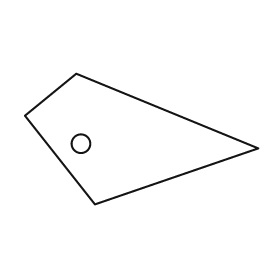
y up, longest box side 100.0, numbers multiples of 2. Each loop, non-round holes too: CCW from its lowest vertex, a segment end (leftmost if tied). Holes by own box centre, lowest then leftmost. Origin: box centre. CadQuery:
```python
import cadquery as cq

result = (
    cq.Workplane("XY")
    .moveTo(-20.0, -28.0)
    .lineTo(50.0, -4.0)
    .lineTo(-28.0, 28.0)
    .lineTo(-50.0, 10.0)
    .close()
    .moveTo(-26.0, -2.0)
    .circle(4.0)
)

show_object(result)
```